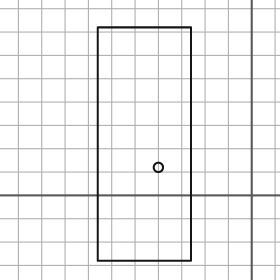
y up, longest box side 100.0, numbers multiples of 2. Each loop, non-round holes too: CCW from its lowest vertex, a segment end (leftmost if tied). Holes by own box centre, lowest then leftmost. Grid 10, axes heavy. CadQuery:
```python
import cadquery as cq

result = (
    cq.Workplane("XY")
    .moveTo(-66.0, -28.0)
    .lineTo(-26.0, -28.0)
    .lineTo(-26.0, 72.0)
    .lineTo(-66.0, 72.0)
    .close()
    .moveTo(-40.0, 12.0)
    .circle(2.0)
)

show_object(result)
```